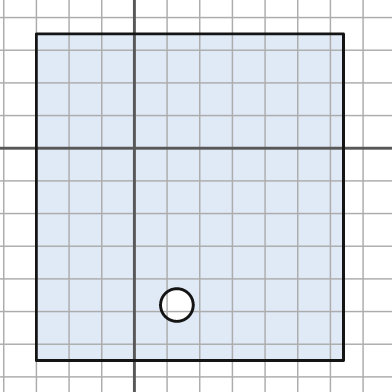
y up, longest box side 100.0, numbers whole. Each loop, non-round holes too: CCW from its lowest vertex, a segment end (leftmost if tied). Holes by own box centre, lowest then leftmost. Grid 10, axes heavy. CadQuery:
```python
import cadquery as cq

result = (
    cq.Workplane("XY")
    .moveTo(-30.0, -65.0)
    .lineTo(64.0, -65.0)
    .lineTo(64.0, 35.0)
    .lineTo(-30.0, 35.0)
    .close()
    .moveTo(13.0, -48.0)
    .circle(5.0)
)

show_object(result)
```